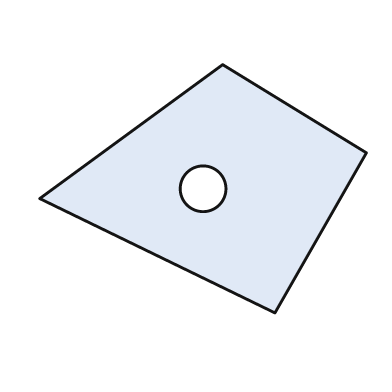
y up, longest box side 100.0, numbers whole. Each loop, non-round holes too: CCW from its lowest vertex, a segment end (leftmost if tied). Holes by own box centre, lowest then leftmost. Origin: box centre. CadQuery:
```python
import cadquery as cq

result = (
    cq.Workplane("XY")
    .moveTo(22.0, -38.0)
    .lineTo(50.0, 11.0)
    .lineTo(6.0, 38.0)
    .lineTo(-50.0, -3.0)
    .close()
    .moveTo(0.0, 0.0)
    .circle(7.0)
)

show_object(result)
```